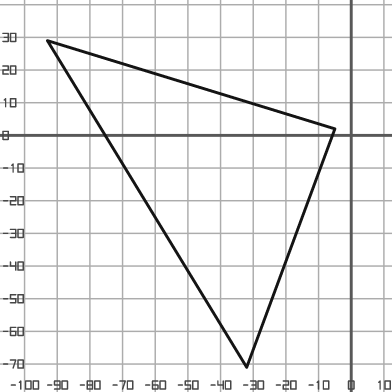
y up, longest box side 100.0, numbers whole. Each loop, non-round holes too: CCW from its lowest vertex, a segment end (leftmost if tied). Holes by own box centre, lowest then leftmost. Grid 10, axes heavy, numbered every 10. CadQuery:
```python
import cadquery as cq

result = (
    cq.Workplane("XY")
    .moveTo(-32.0, -71.0)
    .lineTo(-5.0, 2.0)
    .lineTo(-93.0, 29.0)
    .close()
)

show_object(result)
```